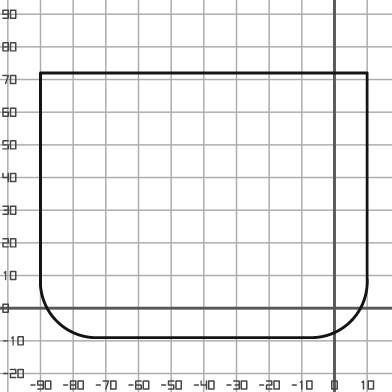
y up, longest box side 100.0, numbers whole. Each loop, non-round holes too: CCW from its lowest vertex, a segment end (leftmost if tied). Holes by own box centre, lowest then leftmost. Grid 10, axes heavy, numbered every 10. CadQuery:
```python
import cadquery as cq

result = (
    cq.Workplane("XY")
    .moveTo(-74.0, -9.0)
    .lineTo(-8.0, -9.0)
    .threePointArc((5.0, -4.0), (10.0, 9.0))
    .lineTo(10.0, 72.0)
    .lineTo(-90.0, 72.0)
    .lineTo(-90.0, 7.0)
    .threePointArc((-85.0, -4.0), (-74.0, -9.0))
    .close()
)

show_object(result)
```